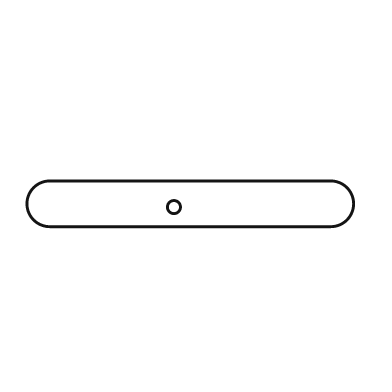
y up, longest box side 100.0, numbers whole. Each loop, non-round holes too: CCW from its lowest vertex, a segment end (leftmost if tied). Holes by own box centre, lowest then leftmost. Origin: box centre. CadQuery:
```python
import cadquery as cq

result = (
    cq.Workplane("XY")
    .moveTo(-43.0, -7.0)
    .lineTo(43.0, -7.0)
    .threePointArc((50.0, 0.0), (43.0, 7.0))
    .lineTo(-43.0, 7.0)
    .threePointArc((-50.0, 0.0), (-43.0, -7.0))
    .close()
    .moveTo(-5.0, -1.0)
    .circle(2.0)
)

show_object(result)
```